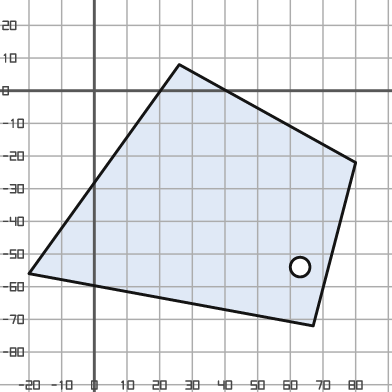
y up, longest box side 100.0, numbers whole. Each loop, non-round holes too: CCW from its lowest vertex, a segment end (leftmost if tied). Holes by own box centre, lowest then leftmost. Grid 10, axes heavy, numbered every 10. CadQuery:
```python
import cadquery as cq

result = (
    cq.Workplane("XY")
    .moveTo(67.0, -72.0)
    .lineTo(80.0, -22.0)
    .lineTo(26.0, 8.0)
    .lineTo(-20.0, -56.0)
    .close()
    .moveTo(63.0, -54.0)
    .circle(3.0)
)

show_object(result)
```